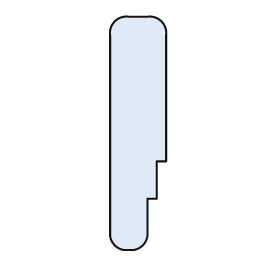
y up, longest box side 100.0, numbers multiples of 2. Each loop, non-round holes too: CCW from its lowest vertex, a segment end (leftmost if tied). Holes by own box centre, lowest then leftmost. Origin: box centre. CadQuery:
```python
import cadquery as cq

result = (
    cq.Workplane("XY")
    .moveTo(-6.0, -50.0)
    .lineTo(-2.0, -50.0)
    .threePointArc((2.0, -48.0), (4.0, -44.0))
    .lineTo(4.0, -28.0)
    .lineTo(8.0, -28.0)
    .lineTo(8.0, -12.0)
    .lineTo(12.0, -12.0)
    .lineTo(12.0, 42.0)
    .threePointArc((10.0, 48.0), (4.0, 50.0))
    .lineTo(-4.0, 50.0)
    .threePointArc((-10.0, 48.0), (-12.0, 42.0))
    .lineTo(-12.0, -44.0)
    .threePointArc((-10.0, -48.0), (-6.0, -50.0))
    .close()
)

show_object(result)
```